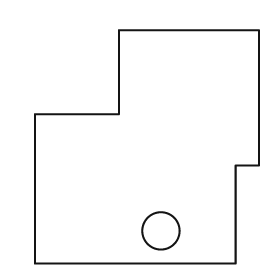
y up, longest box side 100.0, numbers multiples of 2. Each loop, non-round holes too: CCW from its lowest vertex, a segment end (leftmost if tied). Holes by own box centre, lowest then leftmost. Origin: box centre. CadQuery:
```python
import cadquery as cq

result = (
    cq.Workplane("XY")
    .moveTo(-48.0, -50.0)
    .lineTo(38.0, -50.0)
    .lineTo(38.0, -8.0)
    .lineTo(48.0, -8.0)
    .lineTo(48.0, 50.0)
    .lineTo(-12.0, 50.0)
    .lineTo(-12.0, 14.0)
    .lineTo(-48.0, 14.0)
    .close()
    .moveTo(6.0, -36.0)
    .circle(8.0)
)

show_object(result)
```